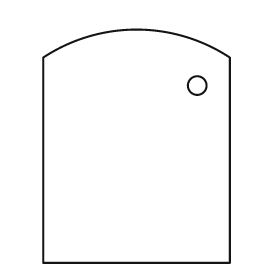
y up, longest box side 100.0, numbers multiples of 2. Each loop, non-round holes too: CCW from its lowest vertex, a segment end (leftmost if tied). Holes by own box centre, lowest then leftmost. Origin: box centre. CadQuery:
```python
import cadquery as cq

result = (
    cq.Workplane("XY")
    .moveTo(-40.0, -50.0)
    .lineTo(40.0, -50.0)
    .lineTo(40.0, 38.0)
    .threePointArc((0.0, 50.0), (-40.0, 38.0))
    .close()
    .moveTo(26.0, 26.0)
    .circle(4.0)
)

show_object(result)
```